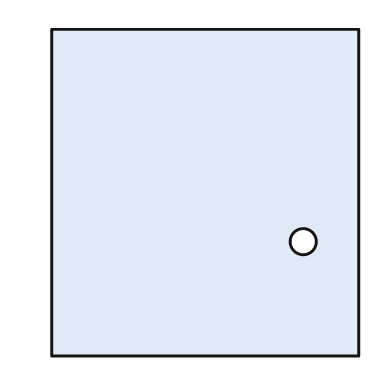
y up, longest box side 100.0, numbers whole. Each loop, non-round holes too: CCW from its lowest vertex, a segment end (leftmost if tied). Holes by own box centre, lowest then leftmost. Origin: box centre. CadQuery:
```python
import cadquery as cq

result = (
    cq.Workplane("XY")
    .moveTo(-47.0, -50.0)
    .lineTo(47.0, -50.0)
    .lineTo(47.0, 50.0)
    .lineTo(-47.0, 50.0)
    .close()
    .moveTo(30.0, -15.0)
    .circle(4.0)
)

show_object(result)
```